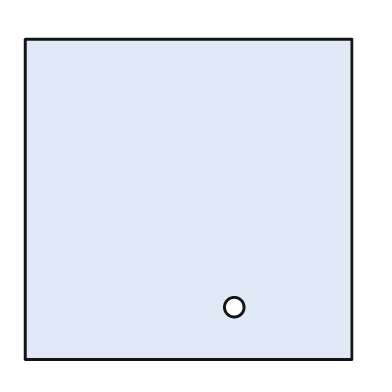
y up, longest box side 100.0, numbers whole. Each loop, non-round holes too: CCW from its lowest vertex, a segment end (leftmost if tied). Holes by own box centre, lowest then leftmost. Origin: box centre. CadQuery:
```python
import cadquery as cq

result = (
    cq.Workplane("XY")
    .moveTo(-50.0, -49.0)
    .lineTo(50.0, -49.0)
    .lineTo(50.0, 49.0)
    .lineTo(-50.0, 49.0)
    .close()
    .moveTo(14.0, -33.0)
    .circle(3.0)
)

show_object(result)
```